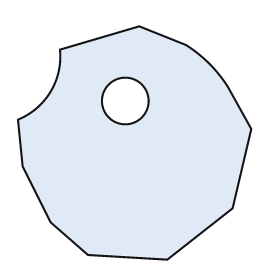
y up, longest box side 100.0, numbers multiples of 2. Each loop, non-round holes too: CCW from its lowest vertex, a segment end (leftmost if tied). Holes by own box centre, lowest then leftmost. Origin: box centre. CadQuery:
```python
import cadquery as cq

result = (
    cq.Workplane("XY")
    .moveTo(14.0, -50.0)
    .lineTo(42.0, -28.0)
    .lineTo(50.0, 6.0)
    .lineTo(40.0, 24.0)
    .threePointArc((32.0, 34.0), (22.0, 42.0))
    .lineTo(2.0, 50.0)
    .lineTo(-32.0, 40.0)
    .threePointArc((-36.0, 22.0), (-50.0, 10.0))
    .lineTo(-48.0, -10.0)
    .lineTo(-36.0, -34.0)
    .lineTo(-20.0, -48.0)
    .close()
    .moveTo(-4.0, 18.0)
    .circle(10.0)
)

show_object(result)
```